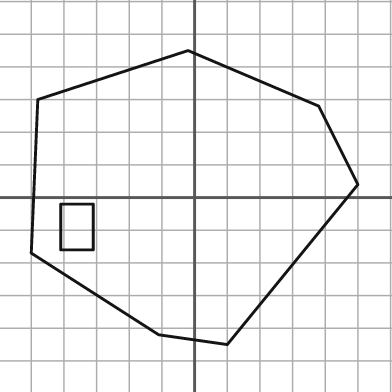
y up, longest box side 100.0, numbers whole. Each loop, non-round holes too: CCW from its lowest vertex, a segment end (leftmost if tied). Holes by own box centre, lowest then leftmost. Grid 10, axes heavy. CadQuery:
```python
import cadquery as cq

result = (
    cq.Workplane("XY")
    .moveTo(10.0, -45.0)
    .lineTo(50.0, 4.0)
    .lineTo(38.0, 28.0)
    .lineTo(-2.0, 45.0)
    .lineTo(-48.0, 30.0)
    .lineTo(-50.0, -17.0)
    .lineTo(-11.0, -42.0)
    .close()
    .moveTo(-41.0, -16.0)
    .lineTo(-31.0, -16.0)
    .lineTo(-31.0, -2.0)
    .lineTo(-41.0, -2.0)
    .close()
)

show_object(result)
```